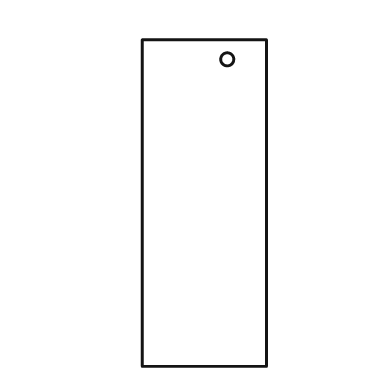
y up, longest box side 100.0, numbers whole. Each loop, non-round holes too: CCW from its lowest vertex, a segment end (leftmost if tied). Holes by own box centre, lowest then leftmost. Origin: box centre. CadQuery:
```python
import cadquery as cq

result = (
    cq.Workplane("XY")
    .moveTo(-19.0, -50.0)
    .lineTo(19.0, -50.0)
    .lineTo(19.0, 50.0)
    .lineTo(-19.0, 50.0)
    .close()
    .moveTo(7.0, 44.0)
    .circle(2.0)
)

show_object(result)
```